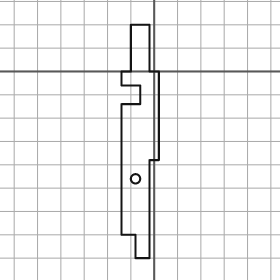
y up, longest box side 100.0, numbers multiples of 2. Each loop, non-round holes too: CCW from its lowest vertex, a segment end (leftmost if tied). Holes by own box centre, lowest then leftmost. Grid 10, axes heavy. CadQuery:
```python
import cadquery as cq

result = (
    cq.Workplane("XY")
    .moveTo(-8.0, -80.0)
    .lineTo(-2.0, -80.0)
    .lineTo(-2.0, -38.0)
    .lineTo(2.0, -38.0)
    .lineTo(2.0, 0.0)
    .lineTo(-2.0, 0.0)
    .lineTo(-2.0, 20.0)
    .lineTo(-10.0, 20.0)
    .lineTo(-10.0, 0.0)
    .lineTo(-14.0, 0.0)
    .lineTo(-14.0, -6.0)
    .lineTo(-6.0, -6.0)
    .lineTo(-6.0, -14.0)
    .lineTo(-14.0, -14.0)
    .lineTo(-14.0, -70.0)
    .lineTo(-8.0, -70.0)
    .close()
    .moveTo(-8.0, -46.0)
    .circle(2.0)
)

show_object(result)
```